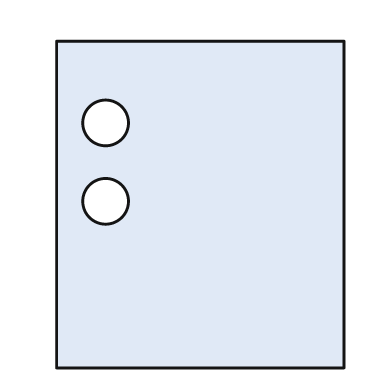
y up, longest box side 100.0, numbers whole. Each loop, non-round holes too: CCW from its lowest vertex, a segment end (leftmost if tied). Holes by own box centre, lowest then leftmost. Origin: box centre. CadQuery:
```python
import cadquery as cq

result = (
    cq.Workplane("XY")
    .moveTo(-44.0, -50.0)
    .lineTo(44.0, -50.0)
    .lineTo(44.0, 50.0)
    .lineTo(-44.0, 50.0)
    .close()
    .moveTo(-29.0, 1.0)
    .circle(7.0)
    .moveTo(-29.0, 25.0)
    .circle(7.0)
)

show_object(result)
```